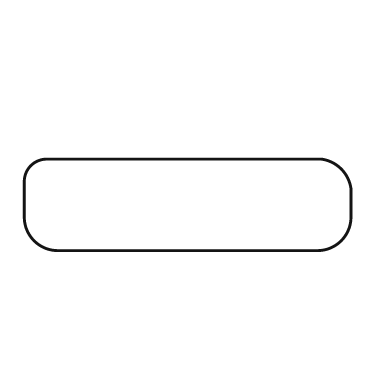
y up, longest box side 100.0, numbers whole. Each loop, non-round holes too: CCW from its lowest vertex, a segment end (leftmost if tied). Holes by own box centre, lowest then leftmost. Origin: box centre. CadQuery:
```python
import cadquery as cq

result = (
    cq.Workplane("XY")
    .moveTo(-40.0, -14.0)
    .lineTo(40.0, -14.0)
    .threePointArc((47.0, -11.0), (50.0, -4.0))
    .lineTo(50.0, 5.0)
    .threePointArc((47.0, 11.0), (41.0, 14.0))
    .lineTo(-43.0, 14.0)
    .threePointArc((-48.0, 12.0), (-50.0, 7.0))
    .lineTo(-50.0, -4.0)
    .threePointArc((-47.0, -11.0), (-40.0, -14.0))
    .close()
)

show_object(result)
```